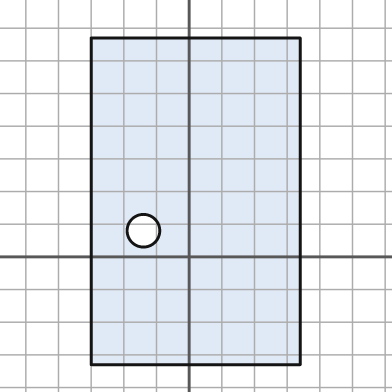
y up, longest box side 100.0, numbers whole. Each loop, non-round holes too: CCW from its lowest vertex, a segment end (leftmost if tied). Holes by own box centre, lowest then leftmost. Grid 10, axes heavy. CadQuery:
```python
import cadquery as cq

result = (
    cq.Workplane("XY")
    .moveTo(-30.0, -33.0)
    .lineTo(34.0, -33.0)
    .lineTo(34.0, 67.0)
    .lineTo(-30.0, 67.0)
    .close()
    .moveTo(-14.0, 8.0)
    .circle(5.0)
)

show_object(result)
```